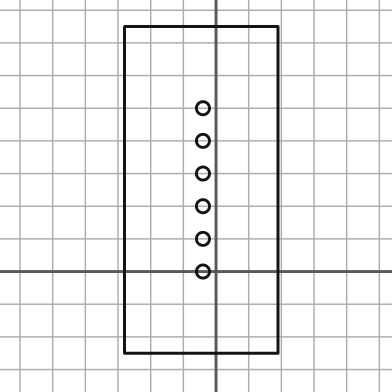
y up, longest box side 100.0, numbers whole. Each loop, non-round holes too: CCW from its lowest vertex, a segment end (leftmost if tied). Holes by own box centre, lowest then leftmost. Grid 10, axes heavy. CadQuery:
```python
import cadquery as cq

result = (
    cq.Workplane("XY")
    .moveTo(-28.0, -25.0)
    .lineTo(19.0, -25.0)
    .lineTo(19.0, 75.0)
    .lineTo(-28.0, 75.0)
    .close()
    .moveTo(-4.0, 0.0)
    .circle(2.0)
    .moveTo(-4.0, 10.0)
    .circle(2.0)
    .moveTo(-4.0, 20.0)
    .circle(2.0)
    .moveTo(-4.0, 30.0)
    .circle(2.0)
    .moveTo(-4.0, 40.0)
    .circle(2.0)
    .moveTo(-4.0, 50.0)
    .circle(2.0)
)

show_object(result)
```